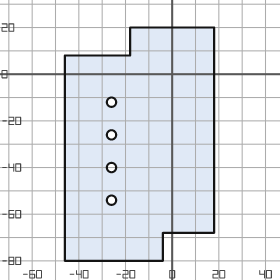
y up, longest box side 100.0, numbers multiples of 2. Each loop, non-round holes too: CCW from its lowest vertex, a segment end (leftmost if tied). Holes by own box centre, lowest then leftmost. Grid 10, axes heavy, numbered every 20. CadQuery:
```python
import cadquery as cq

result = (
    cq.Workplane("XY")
    .moveTo(-46.0, -80.0)
    .lineTo(-4.0, -80.0)
    .lineTo(-4.0, -68.0)
    .lineTo(18.0, -68.0)
    .lineTo(18.0, 20.0)
    .lineTo(-18.0, 20.0)
    .lineTo(-18.0, 8.0)
    .lineTo(-46.0, 8.0)
    .close()
    .moveTo(-26.0, -54.0)
    .circle(2.0)
    .moveTo(-26.0, -40.0)
    .circle(2.0)
    .moveTo(-26.0, -26.0)
    .circle(2.0)
    .moveTo(-26.0, -12.0)
    .circle(2.0)
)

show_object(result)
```